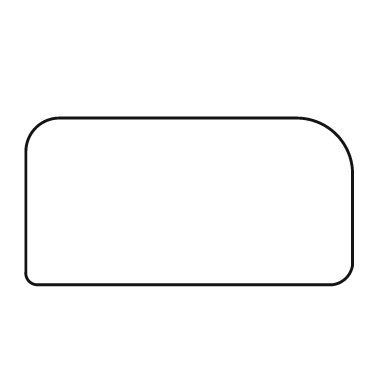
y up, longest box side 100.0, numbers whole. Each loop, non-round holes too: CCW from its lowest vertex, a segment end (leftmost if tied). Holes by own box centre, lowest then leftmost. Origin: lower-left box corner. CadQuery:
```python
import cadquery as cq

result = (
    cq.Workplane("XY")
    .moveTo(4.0, 0.0)
    .lineTo(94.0, 0.0)
    .threePointArc((98.0, 2.0), (100.0, 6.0))
    .lineTo(100.0, 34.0)
    .threePointArc((95.0, 46.0), (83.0, 51.0))
    .lineTo(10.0, 51.0)
    .threePointArc((3.0, 48.0), (0.0, 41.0))
    .lineTo(0.0, 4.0)
    .threePointArc((1.0, 1.0), (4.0, 0.0))
    .close()
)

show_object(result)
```